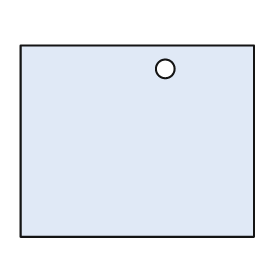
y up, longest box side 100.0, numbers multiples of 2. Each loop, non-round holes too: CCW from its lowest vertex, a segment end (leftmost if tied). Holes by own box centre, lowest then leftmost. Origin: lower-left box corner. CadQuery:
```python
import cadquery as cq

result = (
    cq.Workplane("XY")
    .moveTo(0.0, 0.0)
    .lineTo(100.0, 0.0)
    .lineTo(100.0, 82.0)
    .lineTo(0.0, 82.0)
    .close()
    .moveTo(62.0, 72.0)
    .circle(4.0)
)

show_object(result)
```